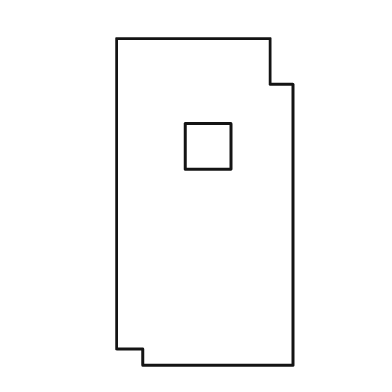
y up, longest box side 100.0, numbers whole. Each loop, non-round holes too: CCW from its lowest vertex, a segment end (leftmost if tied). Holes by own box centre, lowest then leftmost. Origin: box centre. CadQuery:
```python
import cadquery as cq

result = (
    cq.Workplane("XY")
    .moveTo(-19.0, -50.0)
    .lineTo(27.0, -50.0)
    .lineTo(27.0, 36.0)
    .lineTo(20.0, 36.0)
    .lineTo(20.0, 50.0)
    .lineTo(-27.0, 50.0)
    .lineTo(-27.0, -45.0)
    .lineTo(-19.0, -45.0)
    .close()
    .moveTo(-6.0, 10.0)
    .lineTo(8.0, 10.0)
    .lineTo(8.0, 24.0)
    .lineTo(-6.0, 24.0)
    .close()
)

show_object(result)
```